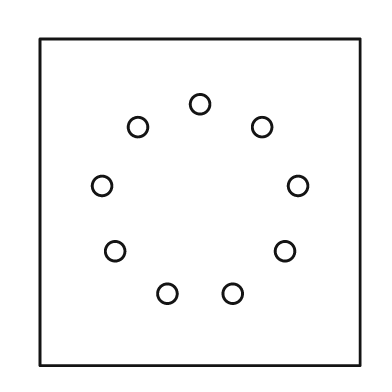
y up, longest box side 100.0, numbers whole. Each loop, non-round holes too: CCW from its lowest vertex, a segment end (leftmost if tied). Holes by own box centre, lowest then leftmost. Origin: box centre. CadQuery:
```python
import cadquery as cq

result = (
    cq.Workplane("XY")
    .moveTo(-49.0, -50.0)
    .lineTo(49.0, -50.0)
    .lineTo(49.0, 50.0)
    .lineTo(-49.0, 50.0)
    .close()
    .moveTo(-10.0, -28.0)
    .circle(3.0)
    .moveTo(10.0, -28.0)
    .circle(3.0)
    .moveTo(-26.0, -15.0)
    .circle(3.0)
    .moveTo(26.0, -15.0)
    .circle(3.0)
    .moveTo(-30.0, 5.0)
    .circle(3.0)
    .moveTo(30.0, 5.0)
    .circle(3.0)
    .moveTo(-19.0, 23.0)
    .circle(3.0)
    .moveTo(19.0, 23.0)
    .circle(3.0)
    .moveTo(0.0, 30.0)
    .circle(3.0)
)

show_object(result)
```